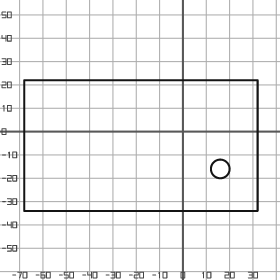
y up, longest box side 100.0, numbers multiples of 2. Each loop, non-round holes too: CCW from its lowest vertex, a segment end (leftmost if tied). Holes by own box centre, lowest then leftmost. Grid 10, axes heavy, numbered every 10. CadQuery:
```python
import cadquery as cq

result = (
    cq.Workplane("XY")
    .moveTo(-68.0, -34.0)
    .lineTo(32.0, -34.0)
    .lineTo(32.0, 22.0)
    .lineTo(-68.0, 22.0)
    .close()
    .moveTo(16.0, -16.0)
    .circle(4.0)
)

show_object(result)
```